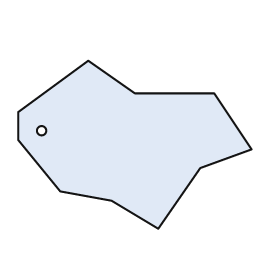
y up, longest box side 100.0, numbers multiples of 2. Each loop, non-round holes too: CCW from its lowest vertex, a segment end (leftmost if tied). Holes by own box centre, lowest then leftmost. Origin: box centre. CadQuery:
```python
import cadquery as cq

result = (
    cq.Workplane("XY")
    .moveTo(10.0, -36.0)
    .lineTo(28.0, -10.0)
    .lineTo(50.0, -2.0)
    .lineTo(34.0, 22.0)
    .lineTo(0.0, 22.0)
    .lineTo(-20.0, 36.0)
    .lineTo(-50.0, 14.0)
    .lineTo(-50.0, 2.0)
    .lineTo(-32.0, -20.0)
    .lineTo(-10.0, -24.0)
    .close()
    .moveTo(-40.0, 6.0)
    .circle(2.0)
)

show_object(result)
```